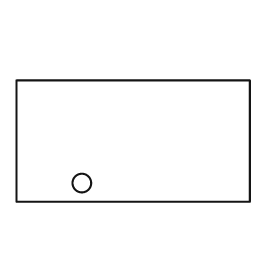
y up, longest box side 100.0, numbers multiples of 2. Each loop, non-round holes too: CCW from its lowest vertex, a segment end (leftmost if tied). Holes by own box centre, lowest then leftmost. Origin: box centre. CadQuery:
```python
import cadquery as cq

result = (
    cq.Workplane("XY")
    .moveTo(-50.0, -26.0)
    .lineTo(50.0, -26.0)
    .lineTo(50.0, 26.0)
    .lineTo(-50.0, 26.0)
    .close()
    .moveTo(-22.0, -18.0)
    .circle(4.0)
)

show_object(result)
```